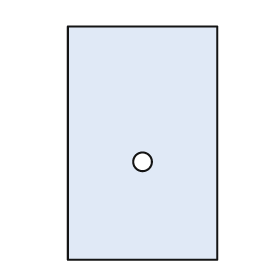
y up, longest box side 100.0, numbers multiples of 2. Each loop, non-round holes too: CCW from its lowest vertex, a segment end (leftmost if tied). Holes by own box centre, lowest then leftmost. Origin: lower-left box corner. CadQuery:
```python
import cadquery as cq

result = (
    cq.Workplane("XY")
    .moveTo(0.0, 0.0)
    .lineTo(64.0, 0.0)
    .lineTo(64.0, 100.0)
    .lineTo(0.0, 100.0)
    .close()
    .moveTo(32.0, 42.0)
    .circle(4.0)
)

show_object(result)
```